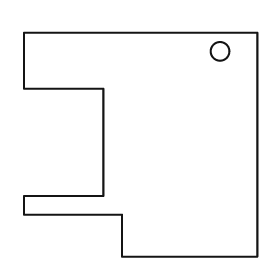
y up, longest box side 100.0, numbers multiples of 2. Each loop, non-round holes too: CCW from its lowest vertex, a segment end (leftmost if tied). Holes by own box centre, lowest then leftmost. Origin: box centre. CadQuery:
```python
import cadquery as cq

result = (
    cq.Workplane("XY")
    .moveTo(-8.0, -48.0)
    .lineTo(50.0, -48.0)
    .lineTo(50.0, 48.0)
    .lineTo(-50.0, 48.0)
    .lineTo(-50.0, 24.0)
    .lineTo(-16.0, 24.0)
    .lineTo(-16.0, -22.0)
    .lineTo(-50.0, -22.0)
    .lineTo(-50.0, -30.0)
    .lineTo(-8.0, -30.0)
    .close()
    .moveTo(34.0, 40.0)
    .circle(4.0)
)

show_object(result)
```